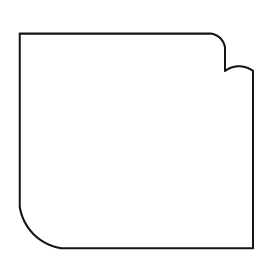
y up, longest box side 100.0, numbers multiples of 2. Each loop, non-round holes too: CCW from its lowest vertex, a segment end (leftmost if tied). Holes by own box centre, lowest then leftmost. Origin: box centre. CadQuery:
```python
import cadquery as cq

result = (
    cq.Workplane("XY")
    .moveTo(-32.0, -46.0)
    .lineTo(50.0, -46.0)
    .lineTo(50.0, 30.0)
    .threePointArc((44.0, 32.0), (38.0, 30.0))
    .lineTo(38.0, 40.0)
    .threePointArc((36.0, 44.0), (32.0, 46.0))
    .lineTo(-50.0, 46.0)
    .lineTo(-50.0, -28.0)
    .threePointArc((-44.0, -40.0), (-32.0, -46.0))
    .close()
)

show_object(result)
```